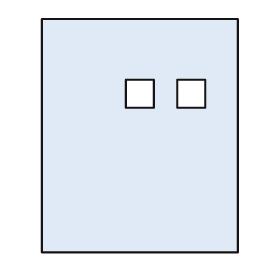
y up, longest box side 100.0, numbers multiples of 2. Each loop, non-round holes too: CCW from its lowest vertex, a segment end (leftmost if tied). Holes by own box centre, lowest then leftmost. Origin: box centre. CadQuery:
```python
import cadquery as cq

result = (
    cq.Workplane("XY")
    .moveTo(-42.0, -50.0)
    .lineTo(42.0, -50.0)
    .lineTo(42.0, 50.0)
    .lineTo(-42.0, 50.0)
    .close()
    .moveTo(-6.0, 12.0)
    .lineTo(6.0, 12.0)
    .lineTo(6.0, 24.0)
    .lineTo(-6.0, 24.0)
    .close()
    .moveTo(16.0, 12.0)
    .lineTo(28.0, 12.0)
    .lineTo(28.0, 24.0)
    .lineTo(16.0, 24.0)
    .close()
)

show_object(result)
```